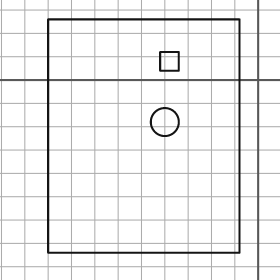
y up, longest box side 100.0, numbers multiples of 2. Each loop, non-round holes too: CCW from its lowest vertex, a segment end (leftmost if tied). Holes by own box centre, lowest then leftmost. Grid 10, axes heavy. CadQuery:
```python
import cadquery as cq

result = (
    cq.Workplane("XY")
    .moveTo(-90.0, -74.0)
    .lineTo(-8.0, -74.0)
    .lineTo(-8.0, 26.0)
    .lineTo(-90.0, 26.0)
    .close()
    .moveTo(-40.0, -18.0)
    .circle(6.0)
    .moveTo(-42.0, 4.0)
    .lineTo(-34.0, 4.0)
    .lineTo(-34.0, 12.0)
    .lineTo(-42.0, 12.0)
    .close()
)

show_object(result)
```